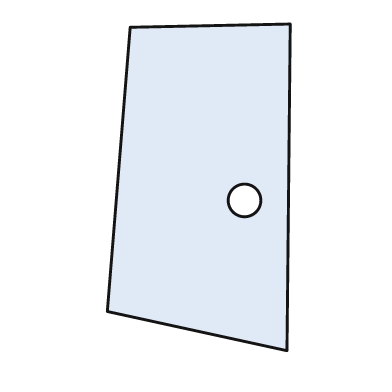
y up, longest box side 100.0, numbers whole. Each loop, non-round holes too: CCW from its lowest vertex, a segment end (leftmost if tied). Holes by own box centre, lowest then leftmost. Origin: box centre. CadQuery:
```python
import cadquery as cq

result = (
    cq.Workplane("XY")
    .moveTo(27.0, -50.0)
    .lineTo(28.0, 50.0)
    .lineTo(-21.0, 49.0)
    .lineTo(-28.0, -38.0)
    .close()
    .moveTo(14.0, -4.0)
    .circle(5.0)
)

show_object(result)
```